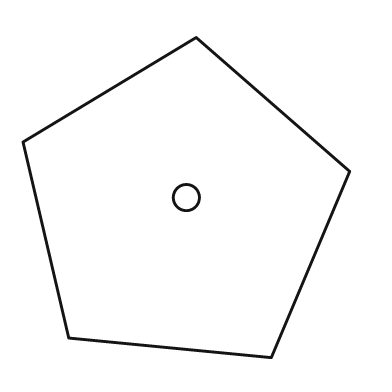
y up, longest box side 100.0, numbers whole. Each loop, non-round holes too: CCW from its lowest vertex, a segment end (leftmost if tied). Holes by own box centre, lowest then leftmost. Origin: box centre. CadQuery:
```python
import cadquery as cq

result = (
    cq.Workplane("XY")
    .moveTo(26.0, -49.0)
    .lineTo(50.0, 8.0)
    .lineTo(3.0, 49.0)
    .lineTo(-50.0, 17.0)
    .lineTo(-36.0, -43.0)
    .close()
    .moveTo(0.0, 0.0)
    .circle(4.0)
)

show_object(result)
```